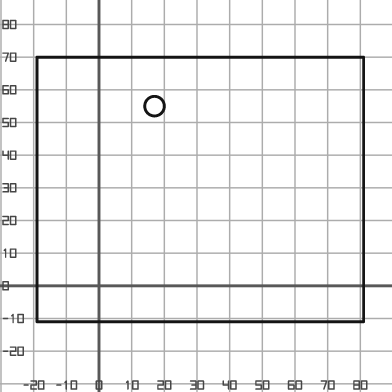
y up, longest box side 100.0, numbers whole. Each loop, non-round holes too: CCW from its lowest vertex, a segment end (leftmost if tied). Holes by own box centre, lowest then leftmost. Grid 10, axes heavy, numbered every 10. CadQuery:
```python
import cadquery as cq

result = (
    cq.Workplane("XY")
    .moveTo(-19.0, -11.0)
    .lineTo(81.0, -11.0)
    .lineTo(81.0, 70.0)
    .lineTo(-19.0, 70.0)
    .close()
    .moveTo(17.0, 55.0)
    .circle(3.0)
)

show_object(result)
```